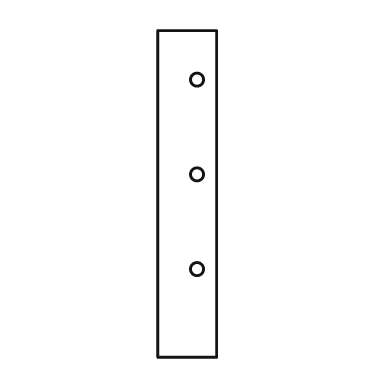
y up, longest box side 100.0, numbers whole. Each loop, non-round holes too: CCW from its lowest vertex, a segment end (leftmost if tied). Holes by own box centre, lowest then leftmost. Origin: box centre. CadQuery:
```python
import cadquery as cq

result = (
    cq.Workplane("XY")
    .moveTo(-9.0, -50.0)
    .lineTo(9.0, -50.0)
    .lineTo(9.0, 50.0)
    .lineTo(-9.0, 50.0)
    .close()
    .moveTo(3.0, -23.0)
    .circle(2.0)
    .moveTo(3.0, 6.0)
    .circle(2.0)
    .moveTo(3.0, 35.0)
    .circle(2.0)
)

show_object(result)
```